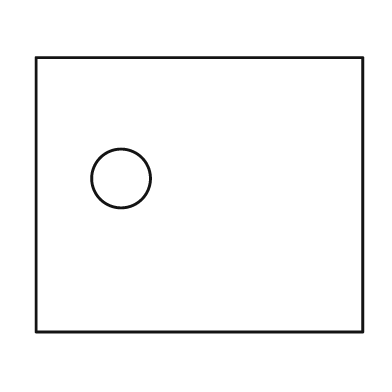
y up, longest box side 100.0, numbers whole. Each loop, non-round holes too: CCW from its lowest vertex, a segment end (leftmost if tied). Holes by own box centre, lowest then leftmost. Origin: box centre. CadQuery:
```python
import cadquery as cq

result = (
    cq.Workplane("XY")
    .moveTo(-50.0, -42.0)
    .lineTo(50.0, -42.0)
    .lineTo(50.0, 42.0)
    .lineTo(-50.0, 42.0)
    .close()
    .moveTo(-24.0, 5.0)
    .circle(9.0)
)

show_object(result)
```